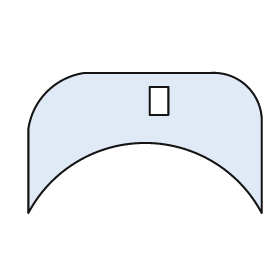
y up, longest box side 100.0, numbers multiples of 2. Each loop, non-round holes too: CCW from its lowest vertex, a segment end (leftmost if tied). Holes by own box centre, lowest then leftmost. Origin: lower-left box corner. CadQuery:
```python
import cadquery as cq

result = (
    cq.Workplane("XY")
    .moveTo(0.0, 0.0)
    .threePointArc((50.0, 30.0), (100.0, 0.0))
    .lineTo(100.0, 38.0)
    .threePointArc((94.0, 54.0), (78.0, 60.0))
    .lineTo(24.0, 60.0)
    .threePointArc((8.0, 52.0), (0.0, 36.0))
    .close()
    .moveTo(52.0, 42.0)
    .lineTo(60.0, 42.0)
    .lineTo(60.0, 54.0)
    .lineTo(52.0, 54.0)
    .close()
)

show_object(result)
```